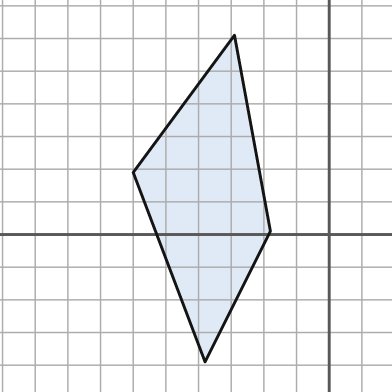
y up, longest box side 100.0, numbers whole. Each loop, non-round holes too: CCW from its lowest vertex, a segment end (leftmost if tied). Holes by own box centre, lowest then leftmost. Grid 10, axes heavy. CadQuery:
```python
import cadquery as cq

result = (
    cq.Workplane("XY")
    .moveTo(-38.0, -39.0)
    .lineTo(-18.0, 1.0)
    .lineTo(-29.0, 61.0)
    .lineTo(-60.0, 19.0)
    .close()
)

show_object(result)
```